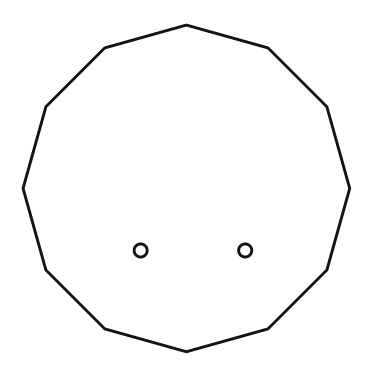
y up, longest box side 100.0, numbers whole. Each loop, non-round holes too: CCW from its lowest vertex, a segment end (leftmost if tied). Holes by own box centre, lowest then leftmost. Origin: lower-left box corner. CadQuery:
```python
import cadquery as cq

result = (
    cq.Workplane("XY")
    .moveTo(50.0, 0.0)
    .lineTo(75.0, 7.0)
    .lineTo(93.0, 25.0)
    .lineTo(100.0, 50.0)
    .lineTo(93.0, 75.0)
    .lineTo(75.0, 93.0)
    .lineTo(50.0, 100.0)
    .lineTo(25.0, 93.0)
    .lineTo(7.0, 75.0)
    .lineTo(0.0, 50.0)
    .lineTo(7.0, 25.0)
    .lineTo(25.0, 7.0)
    .close()
    .moveTo(36.0, 31.0)
    .circle(2.0)
    .moveTo(68.0, 31.0)
    .circle(2.0)
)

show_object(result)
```